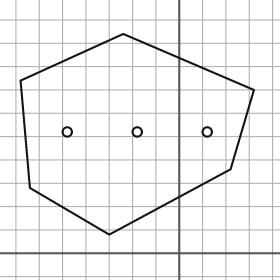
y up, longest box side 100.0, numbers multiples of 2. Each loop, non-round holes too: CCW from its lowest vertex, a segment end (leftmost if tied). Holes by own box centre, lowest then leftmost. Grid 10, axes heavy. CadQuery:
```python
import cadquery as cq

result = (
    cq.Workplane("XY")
    .moveTo(-30.0, 8.0)
    .lineTo(22.0, 36.0)
    .lineTo(32.0, 70.0)
    .lineTo(-24.0, 94.0)
    .lineTo(-68.0, 74.0)
    .lineTo(-64.0, 28.0)
    .close()
    .moveTo(-48.0, 52.0)
    .circle(2.0)
    .moveTo(-18.0, 52.0)
    .circle(2.0)
    .moveTo(12.0, 52.0)
    .circle(2.0)
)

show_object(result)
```